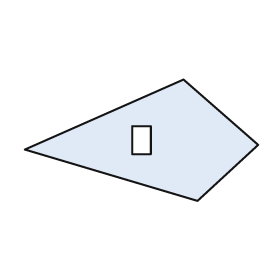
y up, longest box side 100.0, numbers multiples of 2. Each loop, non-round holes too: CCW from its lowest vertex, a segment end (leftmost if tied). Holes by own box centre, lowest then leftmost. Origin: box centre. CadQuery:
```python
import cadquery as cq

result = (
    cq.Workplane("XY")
    .moveTo(24.0, -26.0)
    .lineTo(50.0, -2.0)
    .lineTo(18.0, 26.0)
    .lineTo(-50.0, -4.0)
    .close()
    .moveTo(-4.0, -6.0)
    .lineTo(4.0, -6.0)
    .lineTo(4.0, 6.0)
    .lineTo(-4.0, 6.0)
    .close()
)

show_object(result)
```